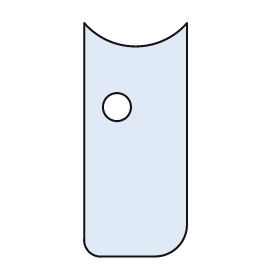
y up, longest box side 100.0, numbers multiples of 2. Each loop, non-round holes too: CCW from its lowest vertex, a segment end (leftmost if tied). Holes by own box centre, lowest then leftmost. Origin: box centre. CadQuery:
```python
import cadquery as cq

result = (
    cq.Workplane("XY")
    .moveTo(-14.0, -50.0)
    .lineTo(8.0, -50.0)
    .threePointArc((18.0, -46.0), (22.0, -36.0))
    .lineTo(22.0, 50.0)
    .threePointArc((0.0, 40.0), (-22.0, 50.0))
    .lineTo(-22.0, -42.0)
    .threePointArc((-20.0, -48.0), (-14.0, -50.0))
    .close()
    .moveTo(-8.0, 14.0)
    .circle(6.0)
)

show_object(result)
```